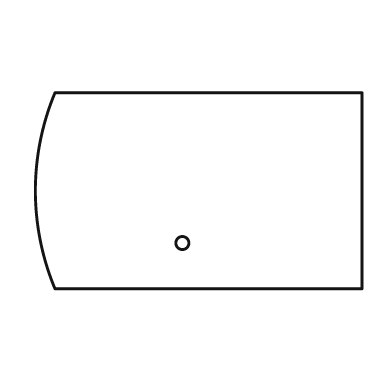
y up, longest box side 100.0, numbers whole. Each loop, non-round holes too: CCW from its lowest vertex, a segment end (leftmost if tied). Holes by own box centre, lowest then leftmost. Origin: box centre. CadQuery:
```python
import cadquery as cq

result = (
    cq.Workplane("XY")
    .moveTo(-44.0, -30.0)
    .lineTo(50.0, -30.0)
    .lineTo(50.0, 30.0)
    .lineTo(-44.0, 30.0)
    .threePointArc((-50.0, 0.0), (-44.0, -30.0))
    .close()
    .moveTo(-5.0, -16.0)
    .circle(2.0)
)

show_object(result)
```